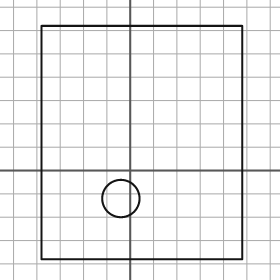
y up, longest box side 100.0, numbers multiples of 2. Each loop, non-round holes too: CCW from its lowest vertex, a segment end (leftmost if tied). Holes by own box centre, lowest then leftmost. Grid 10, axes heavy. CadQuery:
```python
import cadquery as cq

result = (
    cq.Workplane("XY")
    .moveTo(-38.0, -38.0)
    .lineTo(48.0, -38.0)
    .lineTo(48.0, 62.0)
    .lineTo(-38.0, 62.0)
    .close()
    .moveTo(-4.0, -12.0)
    .circle(8.0)
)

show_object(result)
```